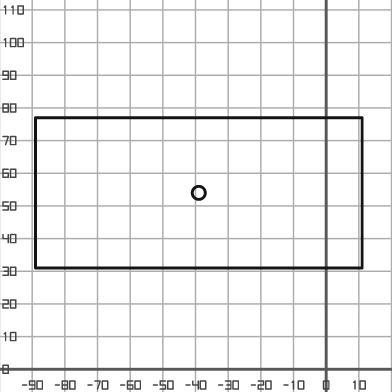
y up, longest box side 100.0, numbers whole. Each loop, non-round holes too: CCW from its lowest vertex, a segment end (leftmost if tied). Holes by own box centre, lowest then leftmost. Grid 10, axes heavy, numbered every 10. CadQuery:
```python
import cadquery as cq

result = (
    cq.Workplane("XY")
    .moveTo(-89.0, 31.0)
    .lineTo(11.0, 31.0)
    .lineTo(11.0, 77.0)
    .lineTo(-89.0, 77.0)
    .close()
    .moveTo(-39.0, 54.0)
    .circle(2.0)
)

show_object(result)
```